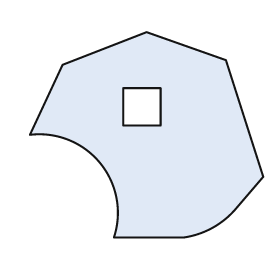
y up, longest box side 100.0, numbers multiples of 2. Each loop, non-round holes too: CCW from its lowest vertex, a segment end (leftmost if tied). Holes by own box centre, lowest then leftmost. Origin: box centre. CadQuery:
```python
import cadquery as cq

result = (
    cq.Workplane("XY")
    .moveTo(-14.0, -44.0)
    .lineTo(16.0, -44.0)
    .threePointArc((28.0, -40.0), (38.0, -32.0))
    .lineTo(50.0, -18.0)
    .lineTo(34.0, 32.0)
    .lineTo(0.0, 44.0)
    .lineTo(-36.0, 30.0)
    .lineTo(-50.0, 0.0)
    .threePointArc((-20.0, -12.0), (-14.0, -44.0))
    .close()
    .moveTo(-10.0, 4.0)
    .lineTo(6.0, 4.0)
    .lineTo(6.0, 20.0)
    .lineTo(-10.0, 20.0)
    .close()
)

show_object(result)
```